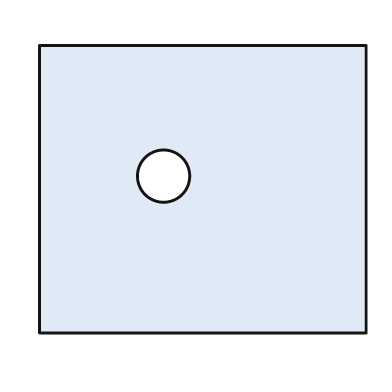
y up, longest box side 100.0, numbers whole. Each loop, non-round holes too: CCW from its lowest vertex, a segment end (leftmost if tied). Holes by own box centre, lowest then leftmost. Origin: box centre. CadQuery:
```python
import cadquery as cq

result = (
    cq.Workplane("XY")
    .moveTo(-50.0, -44.0)
    .lineTo(50.0, -44.0)
    .lineTo(50.0, 44.0)
    .lineTo(-50.0, 44.0)
    .close()
    .moveTo(-12.0, 4.0)
    .circle(8.0)
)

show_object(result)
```